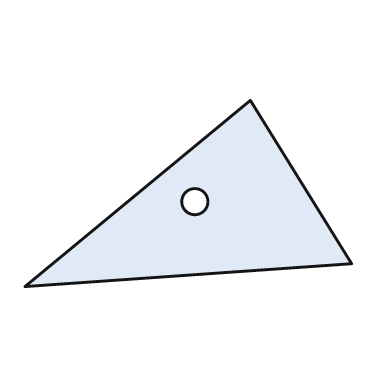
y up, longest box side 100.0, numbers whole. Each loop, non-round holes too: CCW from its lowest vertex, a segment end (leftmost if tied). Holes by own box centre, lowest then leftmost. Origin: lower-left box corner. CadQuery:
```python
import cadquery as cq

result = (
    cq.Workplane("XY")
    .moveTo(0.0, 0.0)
    .lineTo(100.0, 7.0)
    .lineTo(69.0, 57.0)
    .close()
    .moveTo(52.0, 26.0)
    .circle(4.0)
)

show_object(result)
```